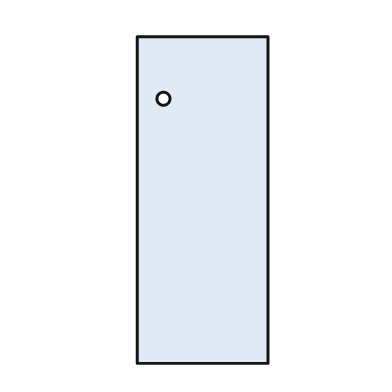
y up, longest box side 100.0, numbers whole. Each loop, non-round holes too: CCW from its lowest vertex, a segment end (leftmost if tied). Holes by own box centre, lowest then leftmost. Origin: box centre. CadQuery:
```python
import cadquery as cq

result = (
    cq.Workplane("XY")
    .moveTo(-20.0, -50.0)
    .lineTo(20.0, -50.0)
    .lineTo(20.0, 50.0)
    .lineTo(-20.0, 50.0)
    .close()
    .moveTo(-12.0, 31.0)
    .circle(2.0)
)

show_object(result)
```